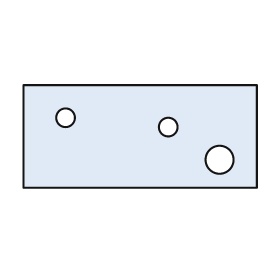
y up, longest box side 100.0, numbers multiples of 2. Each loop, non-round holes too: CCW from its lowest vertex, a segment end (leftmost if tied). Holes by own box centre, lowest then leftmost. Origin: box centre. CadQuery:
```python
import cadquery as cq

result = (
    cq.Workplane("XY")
    .moveTo(-50.0, -22.0)
    .lineTo(50.0, -22.0)
    .lineTo(50.0, 22.0)
    .lineTo(-50.0, 22.0)
    .close()
    .moveTo(34.0, -10.0)
    .circle(6.0)
    .moveTo(12.0, 4.0)
    .circle(4.0)
    .moveTo(-32.0, 8.0)
    .circle(4.0)
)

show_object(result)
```